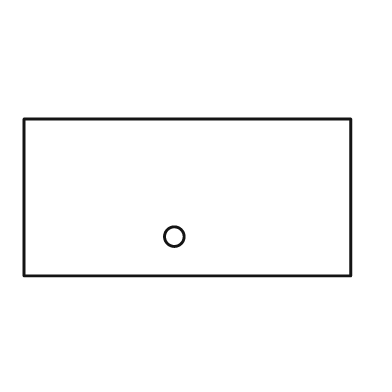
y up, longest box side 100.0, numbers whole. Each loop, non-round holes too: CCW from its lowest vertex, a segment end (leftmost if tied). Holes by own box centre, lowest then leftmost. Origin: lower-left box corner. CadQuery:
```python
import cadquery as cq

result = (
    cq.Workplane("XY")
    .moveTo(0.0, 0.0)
    .lineTo(100.0, 0.0)
    .lineTo(100.0, 48.0)
    .lineTo(0.0, 48.0)
    .close()
    .moveTo(46.0, 12.0)
    .circle(3.0)
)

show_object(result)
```